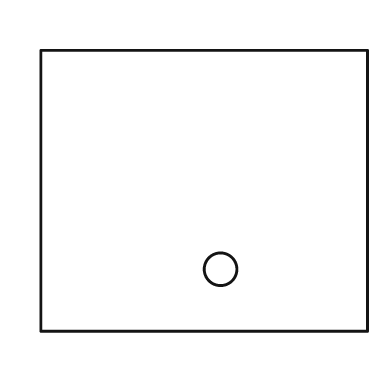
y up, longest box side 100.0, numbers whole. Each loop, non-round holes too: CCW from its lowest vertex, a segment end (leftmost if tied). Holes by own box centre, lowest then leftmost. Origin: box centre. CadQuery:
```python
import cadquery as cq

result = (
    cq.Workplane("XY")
    .moveTo(-50.0, -43.0)
    .lineTo(50.0, -43.0)
    .lineTo(50.0, 43.0)
    .lineTo(-50.0, 43.0)
    .close()
    .moveTo(5.0, -24.0)
    .circle(5.0)
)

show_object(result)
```